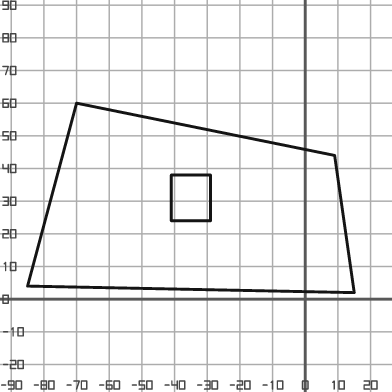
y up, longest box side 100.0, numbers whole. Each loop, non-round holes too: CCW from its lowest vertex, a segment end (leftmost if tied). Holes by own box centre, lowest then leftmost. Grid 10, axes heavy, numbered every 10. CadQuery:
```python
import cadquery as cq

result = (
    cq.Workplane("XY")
    .moveTo(15.0, 2.0)
    .lineTo(9.0, 44.0)
    .lineTo(-70.0, 60.0)
    .lineTo(-85.0, 4.0)
    .close()
    .moveTo(-41.0, 24.0)
    .lineTo(-29.0, 24.0)
    .lineTo(-29.0, 38.0)
    .lineTo(-41.0, 38.0)
    .close()
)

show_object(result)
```